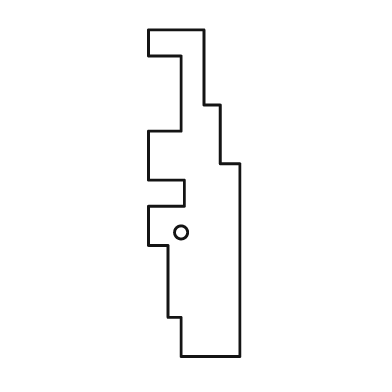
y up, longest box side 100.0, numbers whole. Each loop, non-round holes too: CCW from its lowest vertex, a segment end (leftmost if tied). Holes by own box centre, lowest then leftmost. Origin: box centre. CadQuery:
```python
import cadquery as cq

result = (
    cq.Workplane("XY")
    .moveTo(-4.0, -50.0)
    .lineTo(14.0, -50.0)
    .lineTo(14.0, 9.0)
    .lineTo(8.0, 9.0)
    .lineTo(8.0, 27.0)
    .lineTo(3.0, 27.0)
    .lineTo(3.0, 50.0)
    .lineTo(-14.0, 50.0)
    .lineTo(-14.0, 42.0)
    .lineTo(-4.0, 42.0)
    .lineTo(-4.0, 19.0)
    .lineTo(-14.0, 19.0)
    .lineTo(-14.0, 4.0)
    .lineTo(-3.0, 4.0)
    .lineTo(-3.0, -4.0)
    .lineTo(-14.0, -4.0)
    .lineTo(-14.0, -16.0)
    .lineTo(-8.0, -16.0)
    .lineTo(-8.0, -38.0)
    .lineTo(-4.0, -38.0)
    .close()
    .moveTo(-4.0, -12.0)
    .circle(2.0)
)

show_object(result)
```